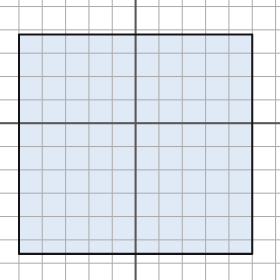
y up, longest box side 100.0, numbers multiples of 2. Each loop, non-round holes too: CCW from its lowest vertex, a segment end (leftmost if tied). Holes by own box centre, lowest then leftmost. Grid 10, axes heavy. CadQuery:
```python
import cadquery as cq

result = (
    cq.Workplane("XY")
    .moveTo(-50.0, -56.0)
    .lineTo(50.0, -56.0)
    .lineTo(50.0, 38.0)
    .lineTo(-50.0, 38.0)
    .close()
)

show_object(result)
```